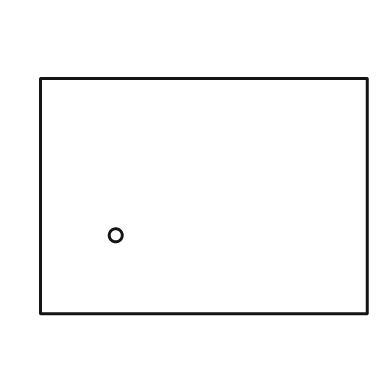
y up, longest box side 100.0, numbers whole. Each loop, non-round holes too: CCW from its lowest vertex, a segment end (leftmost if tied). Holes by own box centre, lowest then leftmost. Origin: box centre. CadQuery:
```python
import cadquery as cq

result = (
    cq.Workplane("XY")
    .moveTo(-50.0, -36.0)
    .lineTo(50.0, -36.0)
    .lineTo(50.0, 36.0)
    .lineTo(-50.0, 36.0)
    .close()
    .moveTo(-27.0, -12.0)
    .circle(2.0)
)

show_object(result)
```